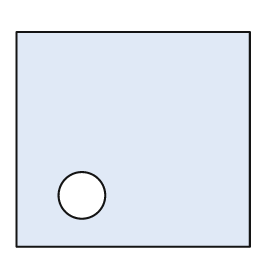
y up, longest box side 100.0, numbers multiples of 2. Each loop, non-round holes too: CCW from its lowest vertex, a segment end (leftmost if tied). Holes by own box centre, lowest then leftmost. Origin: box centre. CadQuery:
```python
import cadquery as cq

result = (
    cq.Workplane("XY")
    .moveTo(-50.0, -46.0)
    .lineTo(50.0, -46.0)
    .lineTo(50.0, 46.0)
    .lineTo(-50.0, 46.0)
    .close()
    .moveTo(-22.0, -24.0)
    .circle(10.0)
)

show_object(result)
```